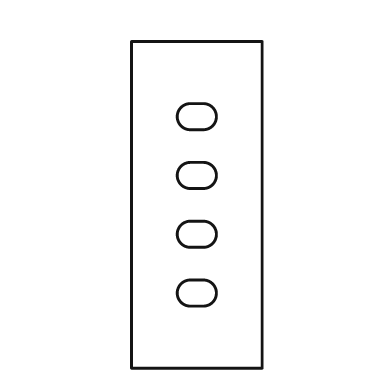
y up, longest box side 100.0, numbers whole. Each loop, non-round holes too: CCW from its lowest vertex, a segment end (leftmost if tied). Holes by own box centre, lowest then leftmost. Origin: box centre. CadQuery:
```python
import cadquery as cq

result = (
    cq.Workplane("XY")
    .moveTo(-20.0, -50.0)
    .lineTo(20.0, -50.0)
    .lineTo(20.0, 50.0)
    .lineTo(-20.0, 50.0)
    .close()
    .moveTo(-2.0, -31.0)
    .lineTo(2.0, -31.0)
    .threePointArc((6.0, -27.0), (2.0, -23.0))
    .lineTo(-2.0, -23.0)
    .threePointArc((-6.0, -27.0), (-2.0, -31.0))
    .close()
    .moveTo(-2.0, -13.0)
    .lineTo(2.0, -13.0)
    .threePointArc((6.0, -9.0), (2.0, -5.0))
    .lineTo(-2.0, -5.0)
    .threePointArc((-6.0, -9.0), (-2.0, -13.0))
    .close()
    .moveTo(-2.0, 5.0)
    .lineTo(2.0, 5.0)
    .threePointArc((6.0, 9.0), (2.0, 13.0))
    .lineTo(-2.0, 13.0)
    .threePointArc((-6.0, 9.0), (-2.0, 5.0))
    .close()
    .moveTo(-2.0, 23.0)
    .lineTo(2.0, 23.0)
    .threePointArc((6.0, 27.0), (2.0, 31.0))
    .lineTo(-2.0, 31.0)
    .threePointArc((-6.0, 27.0), (-2.0, 23.0))
    .close()
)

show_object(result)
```